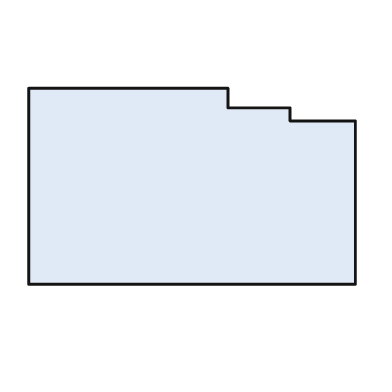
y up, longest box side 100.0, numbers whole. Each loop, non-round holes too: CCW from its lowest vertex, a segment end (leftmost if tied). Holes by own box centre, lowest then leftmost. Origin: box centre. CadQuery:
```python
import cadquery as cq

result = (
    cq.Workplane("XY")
    .moveTo(-50.0, -30.0)
    .lineTo(50.0, -30.0)
    .lineTo(50.0, 20.0)
    .lineTo(30.0, 20.0)
    .lineTo(30.0, 24.0)
    .lineTo(11.0, 24.0)
    .lineTo(11.0, 30.0)
    .lineTo(-50.0, 30.0)
    .close()
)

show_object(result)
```